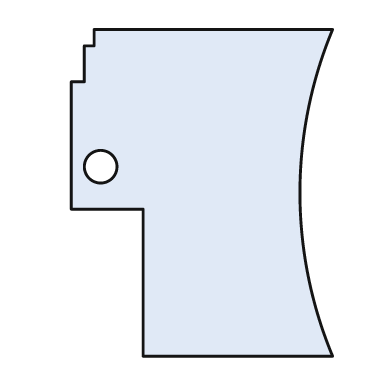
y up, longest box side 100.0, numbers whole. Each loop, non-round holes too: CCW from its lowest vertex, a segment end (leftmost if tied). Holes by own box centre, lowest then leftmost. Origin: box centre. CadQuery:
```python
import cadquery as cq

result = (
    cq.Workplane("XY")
    .moveTo(-18.0, -50.0)
    .lineTo(40.0, -50.0)
    .threePointArc((30.0, 0.0), (40.0, 50.0))
    .lineTo(-33.0, 50.0)
    .lineTo(-33.0, 45.0)
    .lineTo(-36.0, 45.0)
    .lineTo(-36.0, 34.0)
    .lineTo(-40.0, 34.0)
    .lineTo(-40.0, -5.0)
    .lineTo(-18.0, -5.0)
    .close()
    .moveTo(-31.0, 8.0)
    .circle(5.0)
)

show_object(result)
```